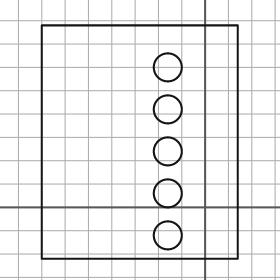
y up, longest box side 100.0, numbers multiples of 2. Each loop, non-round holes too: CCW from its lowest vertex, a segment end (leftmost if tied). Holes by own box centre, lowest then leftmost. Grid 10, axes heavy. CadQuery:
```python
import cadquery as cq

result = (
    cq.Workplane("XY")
    .moveTo(-70.0, -22.0)
    .lineTo(14.0, -22.0)
    .lineTo(14.0, 78.0)
    .lineTo(-70.0, 78.0)
    .close()
    .moveTo(-16.0, -12.0)
    .circle(6.0)
    .moveTo(-16.0, 6.0)
    .circle(6.0)
    .moveTo(-16.0, 24.0)
    .circle(6.0)
    .moveTo(-16.0, 42.0)
    .circle(6.0)
    .moveTo(-16.0, 60.0)
    .circle(6.0)
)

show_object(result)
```